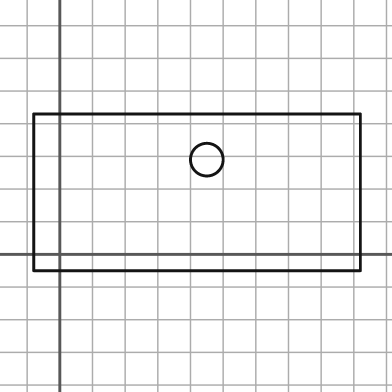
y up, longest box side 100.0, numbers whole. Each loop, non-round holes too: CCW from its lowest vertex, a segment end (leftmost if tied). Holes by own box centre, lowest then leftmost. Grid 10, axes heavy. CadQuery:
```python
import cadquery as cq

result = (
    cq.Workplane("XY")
    .moveTo(-8.0, -5.0)
    .lineTo(92.0, -5.0)
    .lineTo(92.0, 43.0)
    .lineTo(-8.0, 43.0)
    .close()
    .moveTo(45.0, 29.0)
    .circle(5.0)
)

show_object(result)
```